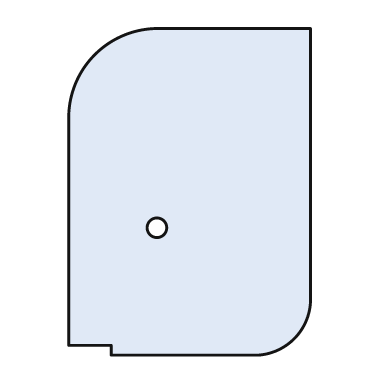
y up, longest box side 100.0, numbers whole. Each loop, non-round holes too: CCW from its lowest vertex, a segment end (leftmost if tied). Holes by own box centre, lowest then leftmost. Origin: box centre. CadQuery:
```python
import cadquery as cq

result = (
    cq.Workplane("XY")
    .moveTo(-24.0, -50.0)
    .lineTo(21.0, -50.0)
    .threePointArc((32.0, -45.0), (37.0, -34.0))
    .lineTo(37.0, 50.0)
    .lineTo(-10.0, 50.0)
    .threePointArc((-29.0, 42.0), (-37.0, 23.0))
    .lineTo(-37.0, -47.0)
    .lineTo(-24.0, -47.0)
    .close()
    .moveTo(-10.0, -11.0)
    .circle(3.0)
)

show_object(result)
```